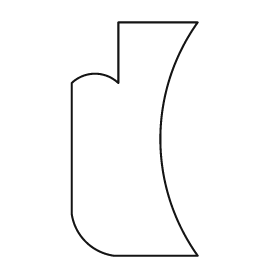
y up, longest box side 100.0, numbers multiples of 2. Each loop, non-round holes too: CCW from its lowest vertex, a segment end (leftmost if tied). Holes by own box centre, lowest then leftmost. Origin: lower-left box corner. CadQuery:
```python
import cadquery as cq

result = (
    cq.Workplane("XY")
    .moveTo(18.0, 0.0)
    .lineTo(54.0, 0.0)
    .threePointArc((38.0, 50.0), (54.0, 100.0))
    .lineTo(20.0, 100.0)
    .lineTo(20.0, 74.0)
    .threePointArc((10.0, 78.0), (0.0, 74.0))
    .lineTo(0.0, 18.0)
    .threePointArc((6.0, 6.0), (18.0, 0.0))
    .close()
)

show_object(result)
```